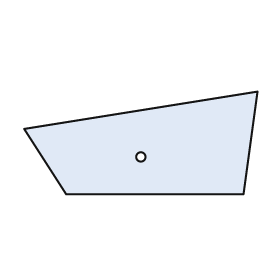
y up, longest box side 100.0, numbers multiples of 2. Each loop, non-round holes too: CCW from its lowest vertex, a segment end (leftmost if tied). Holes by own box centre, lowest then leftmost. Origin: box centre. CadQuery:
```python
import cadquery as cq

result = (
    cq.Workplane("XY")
    .moveTo(-32.0, -22.0)
    .lineTo(44.0, -22.0)
    .lineTo(50.0, 22.0)
    .lineTo(-50.0, 6.0)
    .close()
    .moveTo(0.0, -6.0)
    .circle(2.0)
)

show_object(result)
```